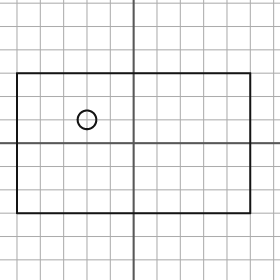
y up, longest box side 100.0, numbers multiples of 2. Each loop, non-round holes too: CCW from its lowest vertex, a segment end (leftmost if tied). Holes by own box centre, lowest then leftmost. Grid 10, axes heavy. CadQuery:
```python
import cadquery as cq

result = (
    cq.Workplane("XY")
    .moveTo(-50.0, -30.0)
    .lineTo(50.0, -30.0)
    .lineTo(50.0, 30.0)
    .lineTo(-50.0, 30.0)
    .close()
    .moveTo(-20.0, 10.0)
    .circle(4.0)
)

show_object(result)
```